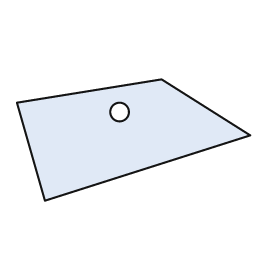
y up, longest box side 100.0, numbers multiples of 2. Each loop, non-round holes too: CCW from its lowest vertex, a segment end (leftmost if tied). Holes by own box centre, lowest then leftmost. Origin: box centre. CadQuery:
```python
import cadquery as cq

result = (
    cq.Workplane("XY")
    .moveTo(-38.0, -26.0)
    .lineTo(50.0, 2.0)
    .lineTo(12.0, 26.0)
    .lineTo(-50.0, 16.0)
    .close()
    .moveTo(-6.0, 12.0)
    .circle(4.0)
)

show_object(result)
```